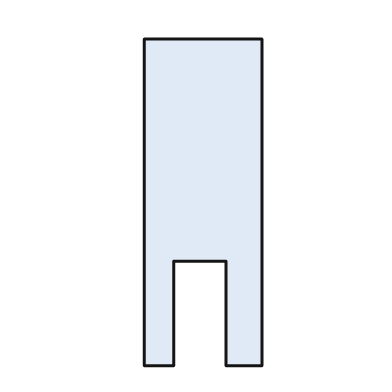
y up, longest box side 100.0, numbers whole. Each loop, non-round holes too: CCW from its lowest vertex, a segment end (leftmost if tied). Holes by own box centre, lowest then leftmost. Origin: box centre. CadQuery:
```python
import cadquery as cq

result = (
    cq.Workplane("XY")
    .moveTo(-18.0, -50.0)
    .lineTo(-9.0, -50.0)
    .lineTo(-9.0, -18.0)
    .lineTo(7.0, -18.0)
    .lineTo(7.0, -50.0)
    .lineTo(18.0, -50.0)
    .lineTo(18.0, 50.0)
    .lineTo(-18.0, 50.0)
    .close()
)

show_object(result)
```